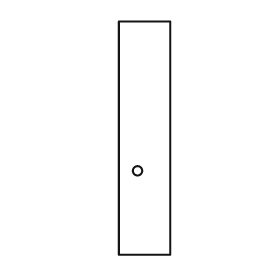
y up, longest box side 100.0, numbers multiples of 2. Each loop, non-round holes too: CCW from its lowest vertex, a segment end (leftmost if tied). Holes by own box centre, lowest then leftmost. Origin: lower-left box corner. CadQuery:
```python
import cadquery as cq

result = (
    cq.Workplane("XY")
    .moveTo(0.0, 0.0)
    .lineTo(22.0, 0.0)
    .lineTo(22.0, 100.0)
    .lineTo(0.0, 100.0)
    .close()
    .moveTo(8.0, 36.0)
    .circle(2.0)
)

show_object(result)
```